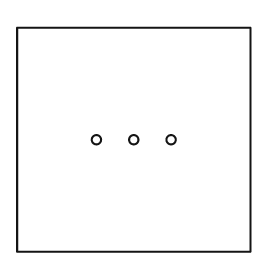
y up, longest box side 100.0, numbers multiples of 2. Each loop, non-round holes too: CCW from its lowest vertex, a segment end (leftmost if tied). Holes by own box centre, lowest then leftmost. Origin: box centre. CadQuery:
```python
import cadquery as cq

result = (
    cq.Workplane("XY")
    .moveTo(-50.0, -48.0)
    .lineTo(50.0, -48.0)
    .lineTo(50.0, 48.0)
    .lineTo(-50.0, 48.0)
    .close()
    .moveTo(-16.0, 0.0)
    .circle(2.0)
    .moveTo(0.0, 0.0)
    .circle(2.0)
    .moveTo(16.0, 0.0)
    .circle(2.0)
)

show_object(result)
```